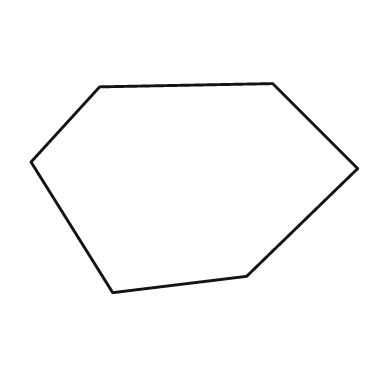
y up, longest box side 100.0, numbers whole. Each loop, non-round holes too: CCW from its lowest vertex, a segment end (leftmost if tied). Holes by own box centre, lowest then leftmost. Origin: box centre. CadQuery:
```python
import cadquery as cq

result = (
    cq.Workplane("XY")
    .moveTo(-25.0, -32.0)
    .lineTo(16.0, -27.0)
    .lineTo(50.0, 6.0)
    .lineTo(24.0, 32.0)
    .lineTo(-29.0, 31.0)
    .lineTo(-50.0, 8.0)
    .close()
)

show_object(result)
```